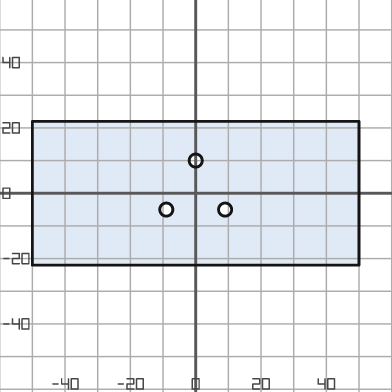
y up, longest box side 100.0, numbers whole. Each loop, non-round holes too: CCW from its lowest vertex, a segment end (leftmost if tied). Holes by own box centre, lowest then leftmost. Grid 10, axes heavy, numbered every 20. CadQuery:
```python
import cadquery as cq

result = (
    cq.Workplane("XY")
    .moveTo(-50.0, -22.0)
    .lineTo(50.0, -22.0)
    .lineTo(50.0, 22.0)
    .lineTo(-50.0, 22.0)
    .close()
    .moveTo(-9.0, -5.0)
    .circle(2.0)
    .moveTo(9.0, -5.0)
    .circle(2.0)
    .moveTo(0.0, 10.0)
    .circle(2.0)
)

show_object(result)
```